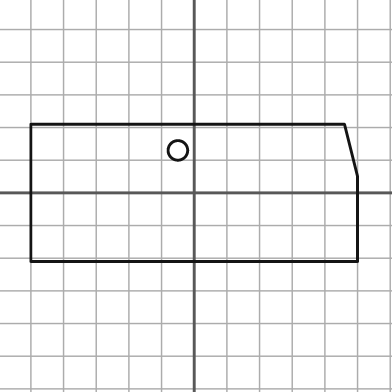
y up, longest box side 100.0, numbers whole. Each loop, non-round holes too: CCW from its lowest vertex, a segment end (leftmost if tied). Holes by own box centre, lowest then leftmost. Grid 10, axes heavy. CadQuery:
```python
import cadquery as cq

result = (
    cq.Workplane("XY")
    .moveTo(-50.0, -21.0)
    .lineTo(50.0, -21.0)
    .lineTo(50.0, 5.0)
    .lineTo(46.0, 21.0)
    .lineTo(-50.0, 21.0)
    .close()
    .moveTo(-5.0, 13.0)
    .circle(3.0)
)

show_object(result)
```